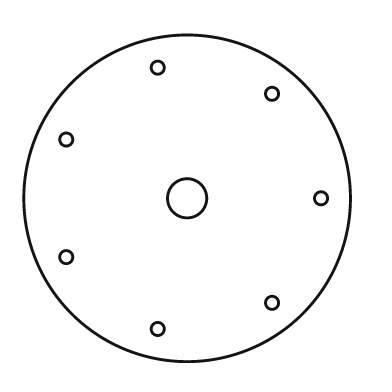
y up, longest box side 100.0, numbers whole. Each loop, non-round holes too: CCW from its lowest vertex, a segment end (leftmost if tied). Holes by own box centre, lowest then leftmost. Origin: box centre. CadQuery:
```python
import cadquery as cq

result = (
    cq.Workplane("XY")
    .moveTo(0.0, 0.0)
    .circle(50.0)
    .moveTo(-9.0, -40.0)
    .circle(2.0)
    .moveTo(26.0, -32.0)
    .circle(2.0)
    .moveTo(-37.0, -18.0)
    .circle(2.0)
    .moveTo(0.0, 0.0)
    .circle(6.0)
    .moveTo(41.0, 0.0)
    .circle(2.0)
    .moveTo(-37.0, 18.0)
    .circle(2.0)
    .moveTo(26.0, 32.0)
    .circle(2.0)
    .moveTo(-9.0, 40.0)
    .circle(2.0)
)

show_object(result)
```